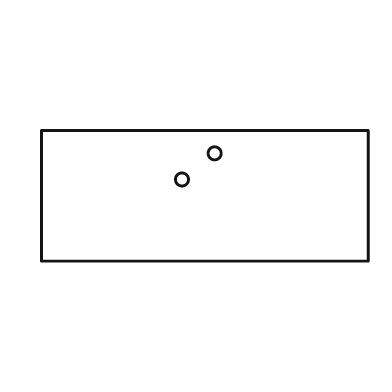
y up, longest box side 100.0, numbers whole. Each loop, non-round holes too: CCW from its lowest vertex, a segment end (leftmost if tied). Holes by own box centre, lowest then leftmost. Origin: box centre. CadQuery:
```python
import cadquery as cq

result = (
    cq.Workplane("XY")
    .moveTo(-50.0, -20.0)
    .lineTo(50.0, -20.0)
    .lineTo(50.0, 20.0)
    .lineTo(-50.0, 20.0)
    .close()
    .moveTo(-7.0, 5.0)
    .circle(2.0)
    .moveTo(3.0, 13.0)
    .circle(2.0)
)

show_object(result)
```